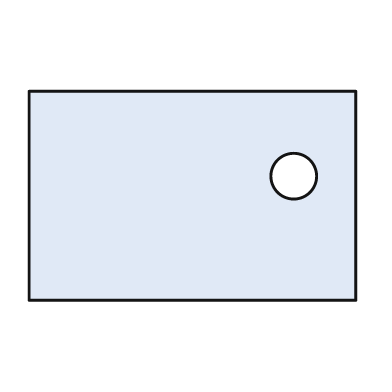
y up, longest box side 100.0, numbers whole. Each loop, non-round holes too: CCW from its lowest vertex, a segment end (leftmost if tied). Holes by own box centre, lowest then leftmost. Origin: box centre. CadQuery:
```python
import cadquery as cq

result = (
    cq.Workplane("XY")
    .moveTo(-50.0, -32.0)
    .lineTo(50.0, -32.0)
    .lineTo(50.0, 32.0)
    .lineTo(-50.0, 32.0)
    .close()
    .moveTo(31.0, 6.0)
    .circle(7.0)
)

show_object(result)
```